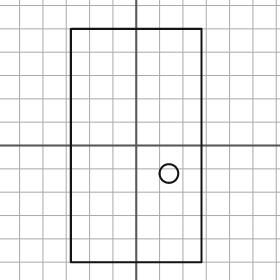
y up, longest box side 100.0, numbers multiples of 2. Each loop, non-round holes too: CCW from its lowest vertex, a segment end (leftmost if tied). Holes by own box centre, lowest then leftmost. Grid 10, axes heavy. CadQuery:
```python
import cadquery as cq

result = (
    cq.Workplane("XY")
    .moveTo(-28.0, -50.0)
    .lineTo(28.0, -50.0)
    .lineTo(28.0, 50.0)
    .lineTo(-28.0, 50.0)
    .close()
    .moveTo(14.0, -12.0)
    .circle(4.0)
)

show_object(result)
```